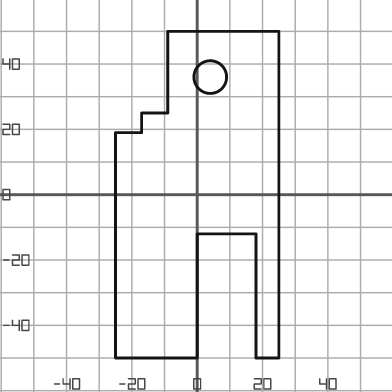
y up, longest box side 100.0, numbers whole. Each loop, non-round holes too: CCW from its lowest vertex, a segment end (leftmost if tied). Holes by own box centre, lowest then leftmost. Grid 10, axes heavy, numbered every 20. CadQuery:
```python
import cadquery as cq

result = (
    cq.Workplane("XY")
    .moveTo(-25.0, -50.0)
    .lineTo(0.0, -50.0)
    .lineTo(0.0, -12.0)
    .lineTo(18.0, -12.0)
    .lineTo(18.0, -50.0)
    .lineTo(25.0, -50.0)
    .lineTo(25.0, 50.0)
    .lineTo(-9.0, 50.0)
    .lineTo(-9.0, 25.0)
    .lineTo(-17.0, 25.0)
    .lineTo(-17.0, 19.0)
    .lineTo(-25.0, 19.0)
    .close()
    .moveTo(4.0, 36.0)
    .circle(5.0)
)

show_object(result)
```